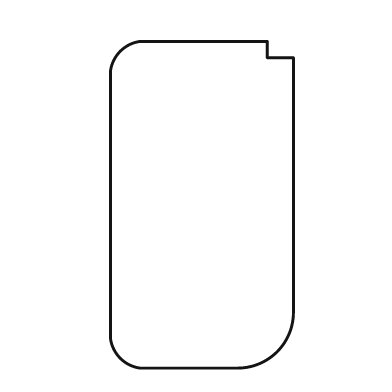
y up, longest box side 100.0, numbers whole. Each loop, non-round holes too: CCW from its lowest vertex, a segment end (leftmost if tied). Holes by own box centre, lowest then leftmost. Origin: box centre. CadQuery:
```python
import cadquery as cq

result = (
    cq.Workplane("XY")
    .moveTo(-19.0, -50.0)
    .lineTo(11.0, -50.0)
    .threePointArc((23.0, -45.0), (28.0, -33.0))
    .lineTo(28.0, 45.0)
    .lineTo(20.0, 45.0)
    .lineTo(20.0, 50.0)
    .lineTo(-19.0, 50.0)
    .threePointArc((-25.0, 47.0), (-28.0, 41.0))
    .lineTo(-28.0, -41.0)
    .threePointArc((-25.0, -47.0), (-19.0, -50.0))
    .close()
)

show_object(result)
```